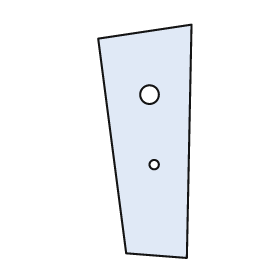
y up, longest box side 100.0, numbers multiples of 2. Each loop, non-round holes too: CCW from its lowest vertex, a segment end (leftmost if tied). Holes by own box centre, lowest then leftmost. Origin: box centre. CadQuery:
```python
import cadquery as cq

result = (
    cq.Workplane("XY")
    .moveTo(18.0, -50.0)
    .lineTo(20.0, 50.0)
    .lineTo(-20.0, 44.0)
    .lineTo(-8.0, -48.0)
    .close()
    .moveTo(4.0, -10.0)
    .circle(2.0)
    .moveTo(2.0, 20.0)
    .circle(4.0)
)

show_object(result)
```